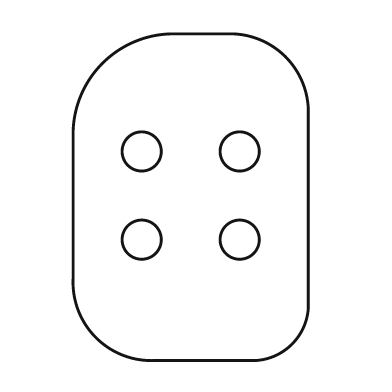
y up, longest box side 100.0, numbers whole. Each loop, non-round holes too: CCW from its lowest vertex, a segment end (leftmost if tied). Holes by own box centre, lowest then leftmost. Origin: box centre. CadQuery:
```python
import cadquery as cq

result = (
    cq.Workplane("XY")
    .moveTo(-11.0, -50.0)
    .lineTo(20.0, -50.0)
    .threePointArc((31.0, -45.0), (36.0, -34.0))
    .lineTo(36.0, 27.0)
    .threePointArc((29.0, 43.0), (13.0, 50.0))
    .lineTo(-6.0, 50.0)
    .threePointArc((-27.0, 41.0), (-36.0, 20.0))
    .lineTo(-36.0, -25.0)
    .threePointArc((-29.0, -43.0), (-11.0, -50.0))
    .close()
    .moveTo(-15.0, -13.0)
    .circle(6.0)
    .moveTo(15.0, -13.0)
    .circle(6.0)
    .moveTo(-15.0, 14.0)
    .circle(6.0)
    .moveTo(15.0, 14.0)
    .circle(6.0)
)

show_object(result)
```